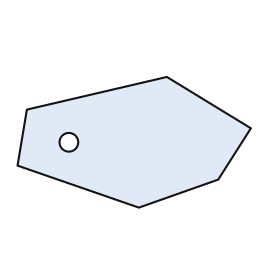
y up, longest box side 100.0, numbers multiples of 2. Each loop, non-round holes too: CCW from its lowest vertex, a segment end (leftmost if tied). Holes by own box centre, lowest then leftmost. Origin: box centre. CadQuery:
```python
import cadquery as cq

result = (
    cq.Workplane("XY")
    .moveTo(2.0, -28.0)
    .lineTo(36.0, -16.0)
    .lineTo(50.0, 6.0)
    .lineTo(14.0, 28.0)
    .lineTo(-46.0, 14.0)
    .lineTo(-50.0, -10.0)
    .close()
    .moveTo(-28.0, 0.0)
    .circle(4.0)
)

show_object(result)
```